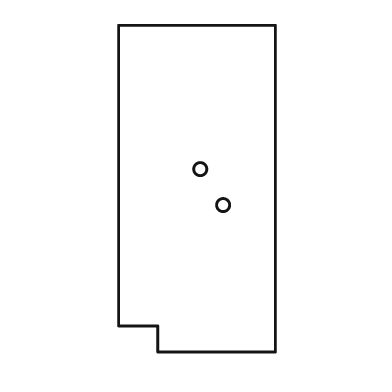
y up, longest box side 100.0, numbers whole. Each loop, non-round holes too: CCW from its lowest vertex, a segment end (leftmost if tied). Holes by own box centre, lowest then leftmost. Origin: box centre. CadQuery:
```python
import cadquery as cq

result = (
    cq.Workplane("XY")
    .moveTo(-12.0, -50.0)
    .lineTo(24.0, -50.0)
    .lineTo(24.0, 50.0)
    .lineTo(-24.0, 50.0)
    .lineTo(-24.0, -42.0)
    .lineTo(-12.0, -42.0)
    .close()
    .moveTo(8.0, -5.0)
    .circle(2.0)
    .moveTo(1.0, 6.0)
    .circle(2.0)
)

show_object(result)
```